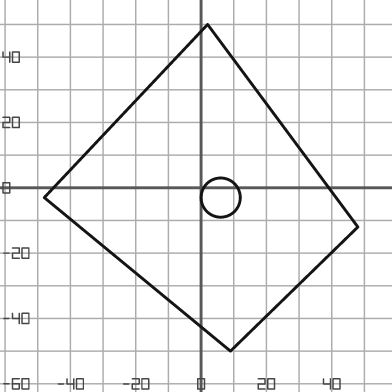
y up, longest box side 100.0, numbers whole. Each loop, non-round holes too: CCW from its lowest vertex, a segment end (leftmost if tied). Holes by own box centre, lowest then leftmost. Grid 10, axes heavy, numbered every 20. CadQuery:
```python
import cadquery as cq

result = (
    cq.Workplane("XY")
    .moveTo(9.0, -50.0)
    .lineTo(48.0, -12.0)
    .lineTo(2.0, 50.0)
    .lineTo(-48.0, -3.0)
    .close()
    .moveTo(6.0, -3.0)
    .circle(6.0)
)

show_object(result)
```